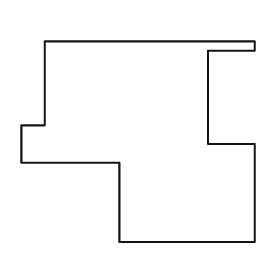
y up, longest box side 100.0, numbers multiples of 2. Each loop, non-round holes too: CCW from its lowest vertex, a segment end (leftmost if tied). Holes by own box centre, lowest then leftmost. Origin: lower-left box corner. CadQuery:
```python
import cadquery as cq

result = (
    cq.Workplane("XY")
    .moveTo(42.0, 0.0)
    .lineTo(100.0, 0.0)
    .lineTo(100.0, 42.0)
    .lineTo(80.0, 42.0)
    .lineTo(80.0, 82.0)
    .lineTo(100.0, 82.0)
    .lineTo(100.0, 86.0)
    .lineTo(10.0, 86.0)
    .lineTo(10.0, 50.0)
    .lineTo(0.0, 50.0)
    .lineTo(0.0, 34.0)
    .lineTo(42.0, 34.0)
    .close()
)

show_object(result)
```